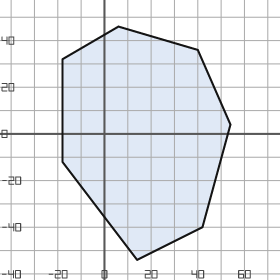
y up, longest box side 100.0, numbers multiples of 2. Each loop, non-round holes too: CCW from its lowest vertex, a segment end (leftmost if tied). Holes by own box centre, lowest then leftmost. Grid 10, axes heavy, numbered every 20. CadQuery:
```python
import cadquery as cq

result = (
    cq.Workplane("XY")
    .moveTo(14.0, -54.0)
    .lineTo(42.0, -40.0)
    .lineTo(54.0, 4.0)
    .lineTo(40.0, 36.0)
    .lineTo(6.0, 46.0)
    .lineTo(-18.0, 32.0)
    .lineTo(-18.0, -12.0)
    .close()
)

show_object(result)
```